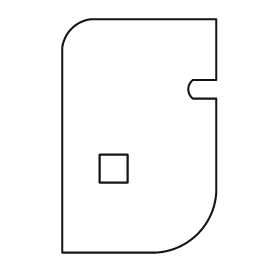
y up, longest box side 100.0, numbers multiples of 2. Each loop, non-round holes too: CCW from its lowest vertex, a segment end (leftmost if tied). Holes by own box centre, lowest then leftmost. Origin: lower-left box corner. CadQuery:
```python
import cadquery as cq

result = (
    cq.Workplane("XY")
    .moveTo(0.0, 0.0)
    .lineTo(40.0, 0.0)
    .threePointArc((58.0, 8.0), (66.0, 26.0))
    .lineTo(66.0, 66.0)
    .lineTo(56.0, 66.0)
    .threePointArc((54.0, 70.0), (56.0, 74.0))
    .lineTo(66.0, 74.0)
    .lineTo(66.0, 100.0)
    .lineTo(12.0, 100.0)
    .threePointArc((4.0, 96.0), (0.0, 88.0))
    .close()
    .moveTo(16.0, 30.0)
    .lineTo(28.0, 30.0)
    .lineTo(28.0, 42.0)
    .lineTo(16.0, 42.0)
    .close()
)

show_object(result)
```